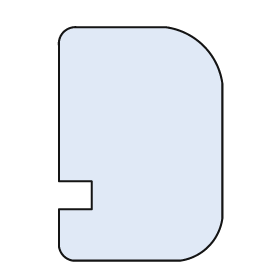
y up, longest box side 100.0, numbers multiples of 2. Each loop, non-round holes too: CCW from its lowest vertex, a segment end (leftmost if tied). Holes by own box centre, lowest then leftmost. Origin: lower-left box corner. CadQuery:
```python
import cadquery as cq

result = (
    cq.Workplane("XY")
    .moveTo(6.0, 0.0)
    .lineTo(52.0, 0.0)
    .threePointArc((64.0, 6.0), (70.0, 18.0))
    .lineTo(70.0, 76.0)
    .threePointArc((62.0, 92.0), (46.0, 100.0))
    .lineTo(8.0, 100.0)
    .threePointArc((2.0, 98.0), (0.0, 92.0))
    .lineTo(0.0, 34.0)
    .lineTo(14.0, 34.0)
    .lineTo(14.0, 22.0)
    .lineTo(0.0, 22.0)
    .lineTo(0.0, 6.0)
    .threePointArc((2.0, 2.0), (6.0, 0.0))
    .close()
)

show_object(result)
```